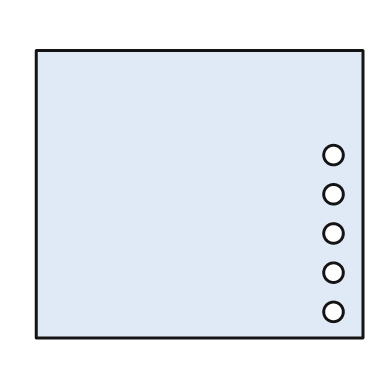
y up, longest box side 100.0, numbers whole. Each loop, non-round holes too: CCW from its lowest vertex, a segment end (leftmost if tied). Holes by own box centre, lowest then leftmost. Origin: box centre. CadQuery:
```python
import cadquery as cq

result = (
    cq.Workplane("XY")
    .moveTo(-50.0, -44.0)
    .lineTo(50.0, -44.0)
    .lineTo(50.0, 44.0)
    .lineTo(-50.0, 44.0)
    .close()
    .moveTo(41.0, -36.0)
    .circle(3.0)
    .moveTo(41.0, -24.0)
    .circle(3.0)
    .moveTo(41.0, -12.0)
    .circle(3.0)
    .moveTo(41.0, 0.0)
    .circle(3.0)
    .moveTo(41.0, 12.0)
    .circle(3.0)
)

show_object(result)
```